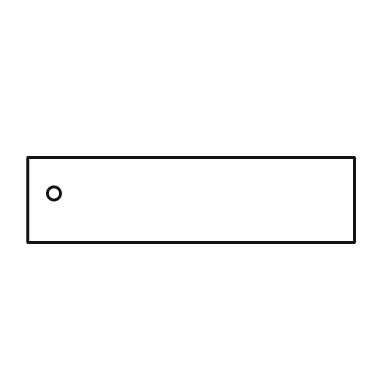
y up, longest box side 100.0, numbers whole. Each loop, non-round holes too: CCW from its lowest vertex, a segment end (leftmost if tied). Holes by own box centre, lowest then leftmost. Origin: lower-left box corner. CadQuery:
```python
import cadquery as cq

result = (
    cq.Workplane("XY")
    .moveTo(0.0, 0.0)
    .lineTo(100.0, 0.0)
    .lineTo(100.0, 26.0)
    .lineTo(0.0, 26.0)
    .close()
    .moveTo(8.0, 15.0)
    .circle(2.0)
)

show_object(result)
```